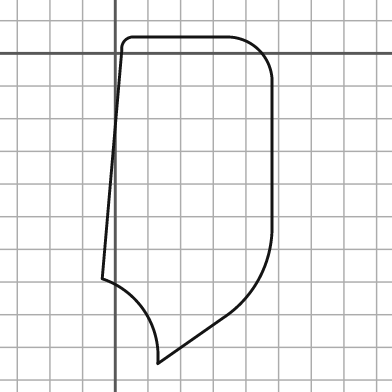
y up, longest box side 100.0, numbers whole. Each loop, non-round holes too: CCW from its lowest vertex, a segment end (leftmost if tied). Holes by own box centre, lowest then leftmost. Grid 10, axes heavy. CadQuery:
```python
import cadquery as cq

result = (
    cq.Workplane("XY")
    .moveTo(13.0, -95.0)
    .lineTo(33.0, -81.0)
    .threePointArc((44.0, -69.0), (48.0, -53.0))
    .lineTo(48.0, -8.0)
    .threePointArc((44.0, 1.0), (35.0, 5.0))
    .lineTo(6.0, 5.0)
    .threePointArc((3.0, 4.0), (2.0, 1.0))
    .lineTo(-4.0, -69.0)
    .threePointArc((9.0, -79.0), (13.0, -95.0))
    .close()
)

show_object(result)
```